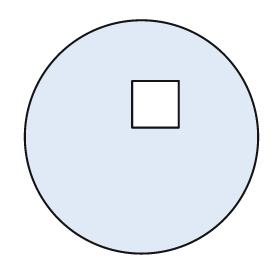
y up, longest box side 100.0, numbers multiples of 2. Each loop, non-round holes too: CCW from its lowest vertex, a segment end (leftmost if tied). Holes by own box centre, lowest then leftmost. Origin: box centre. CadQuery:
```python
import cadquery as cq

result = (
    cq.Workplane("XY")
    .moveTo(0.0, 0.0)
    .circle(50.0)
    .moveTo(-4.0, 4.0)
    .lineTo(16.0, 4.0)
    .lineTo(16.0, 24.0)
    .lineTo(-4.0, 24.0)
    .close()
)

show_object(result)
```